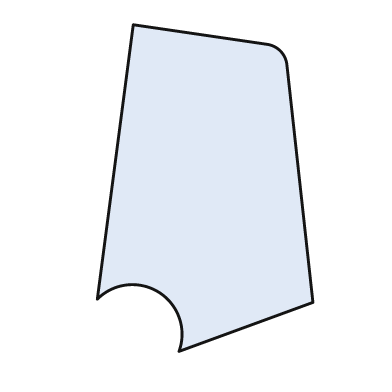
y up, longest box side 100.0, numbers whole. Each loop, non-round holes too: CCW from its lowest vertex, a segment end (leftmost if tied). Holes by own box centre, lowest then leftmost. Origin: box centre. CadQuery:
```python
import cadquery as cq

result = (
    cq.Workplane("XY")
    .moveTo(-8.0, -50.0)
    .lineTo(33.0, -35.0)
    .lineTo(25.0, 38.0)
    .threePointArc((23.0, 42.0), (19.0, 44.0))
    .lineTo(-22.0, 50.0)
    .lineTo(-33.0, -34.0)
    .threePointArc((-14.0, -32.0), (-8.0, -50.0))
    .close()
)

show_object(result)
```